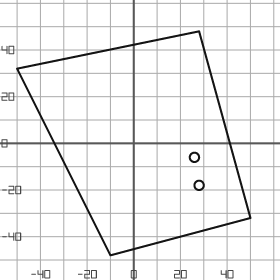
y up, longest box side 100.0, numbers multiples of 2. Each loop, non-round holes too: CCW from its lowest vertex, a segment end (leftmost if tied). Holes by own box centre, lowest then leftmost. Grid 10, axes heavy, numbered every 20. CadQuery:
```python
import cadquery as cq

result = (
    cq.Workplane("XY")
    .moveTo(-10.0, -48.0)
    .lineTo(50.0, -32.0)
    .lineTo(28.0, 48.0)
    .lineTo(-50.0, 32.0)
    .close()
    .moveTo(28.0, -18.0)
    .circle(2.0)
    .moveTo(26.0, -6.0)
    .circle(2.0)
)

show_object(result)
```